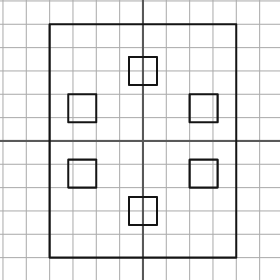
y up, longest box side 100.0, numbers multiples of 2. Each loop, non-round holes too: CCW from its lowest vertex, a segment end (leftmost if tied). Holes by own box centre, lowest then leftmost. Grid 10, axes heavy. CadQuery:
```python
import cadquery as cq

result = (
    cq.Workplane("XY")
    .moveTo(-40.0, -50.0)
    .lineTo(40.0, -50.0)
    .lineTo(40.0, 50.0)
    .lineTo(-40.0, 50.0)
    .close()
    .moveTo(-6.0, -36.0)
    .lineTo(6.0, -36.0)
    .lineTo(6.0, -24.0)
    .lineTo(-6.0, -24.0)
    .close()
    .moveTo(-32.0, -20.0)
    .lineTo(-20.0, -20.0)
    .lineTo(-20.0, -8.0)
    .lineTo(-32.0, -8.0)
    .close()
    .moveTo(20.0, -20.0)
    .lineTo(32.0, -20.0)
    .lineTo(32.0, -8.0)
    .lineTo(20.0, -8.0)
    .close()
    .moveTo(-32.0, 8.0)
    .lineTo(-20.0, 8.0)
    .lineTo(-20.0, 20.0)
    .lineTo(-32.0, 20.0)
    .close()
    .moveTo(20.0, 8.0)
    .lineTo(32.0, 8.0)
    .lineTo(32.0, 20.0)
    .lineTo(20.0, 20.0)
    .close()
    .moveTo(-6.0, 24.0)
    .lineTo(6.0, 24.0)
    .lineTo(6.0, 36.0)
    .lineTo(-6.0, 36.0)
    .close()
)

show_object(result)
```